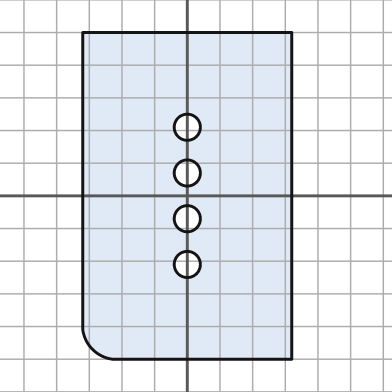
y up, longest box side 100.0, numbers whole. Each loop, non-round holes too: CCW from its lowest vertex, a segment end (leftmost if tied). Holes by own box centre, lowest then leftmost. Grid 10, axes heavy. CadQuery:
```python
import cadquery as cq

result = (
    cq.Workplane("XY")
    .moveTo(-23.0, -50.0)
    .lineTo(32.0, -50.0)
    .lineTo(32.0, 50.0)
    .lineTo(-32.0, 50.0)
    .lineTo(-32.0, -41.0)
    .threePointArc((-29.0, -47.0), (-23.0, -50.0))
    .close()
    .moveTo(0.0, -21.0)
    .circle(4.0)
    .moveTo(0.0, -7.0)
    .circle(4.0)
    .moveTo(0.0, 7.0)
    .circle(4.0)
    .moveTo(0.0, 21.0)
    .circle(4.0)
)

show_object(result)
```